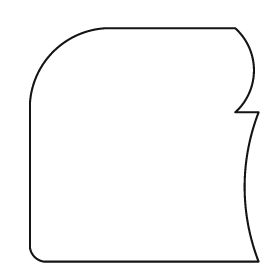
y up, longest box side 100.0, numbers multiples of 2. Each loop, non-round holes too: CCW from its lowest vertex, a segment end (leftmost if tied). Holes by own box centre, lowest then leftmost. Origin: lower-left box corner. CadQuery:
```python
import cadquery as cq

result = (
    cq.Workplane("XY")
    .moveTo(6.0, 0.0)
    .lineTo(98.0, 0.0)
    .threePointArc((92.0, 32.0), (98.0, 64.0))
    .lineTo(88.0, 64.0)
    .threePointArc((96.0, 82.0), (88.0, 100.0))
    .lineTo(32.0, 100.0)
    .threePointArc((10.0, 90.0), (0.0, 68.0))
    .lineTo(0.0, 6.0)
    .threePointArc((2.0, 2.0), (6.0, 0.0))
    .close()
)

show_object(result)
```